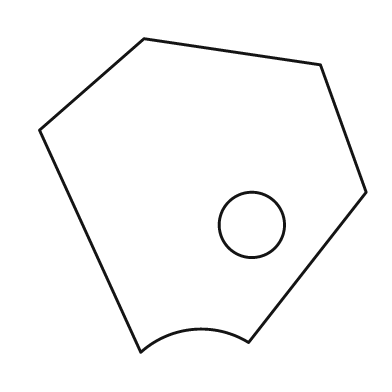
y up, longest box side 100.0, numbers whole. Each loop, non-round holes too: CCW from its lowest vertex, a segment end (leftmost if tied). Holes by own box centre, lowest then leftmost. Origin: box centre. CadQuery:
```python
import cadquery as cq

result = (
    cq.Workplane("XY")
    .moveTo(-19.0, -48.0)
    .threePointArc((-3.0, -41.0), (14.0, -45.0))
    .lineTo(50.0, 1.0)
    .lineTo(36.0, 40.0)
    .lineTo(-18.0, 48.0)
    .lineTo(-50.0, 20.0)
    .close()
    .moveTo(15.0, -9.0)
    .circle(10.0)
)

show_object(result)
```